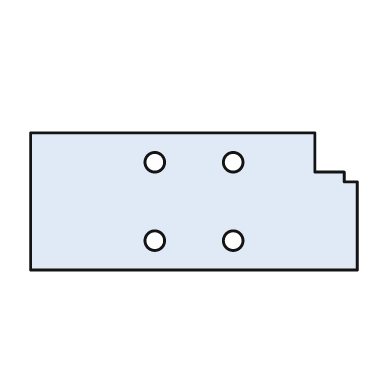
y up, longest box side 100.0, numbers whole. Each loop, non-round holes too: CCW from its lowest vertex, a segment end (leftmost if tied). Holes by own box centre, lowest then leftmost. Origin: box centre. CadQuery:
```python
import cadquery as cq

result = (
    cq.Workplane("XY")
    .moveTo(-50.0, -21.0)
    .lineTo(50.0, -21.0)
    .lineTo(50.0, 6.0)
    .lineTo(46.0, 6.0)
    .lineTo(46.0, 9.0)
    .lineTo(37.0, 9.0)
    .lineTo(37.0, 21.0)
    .lineTo(-50.0, 21.0)
    .close()
    .moveTo(-12.0, -12.0)
    .circle(3.0)
    .moveTo(12.0, -12.0)
    .circle(3.0)
    .moveTo(-12.0, 12.0)
    .circle(3.0)
    .moveTo(12.0, 12.0)
    .circle(3.0)
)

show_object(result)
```